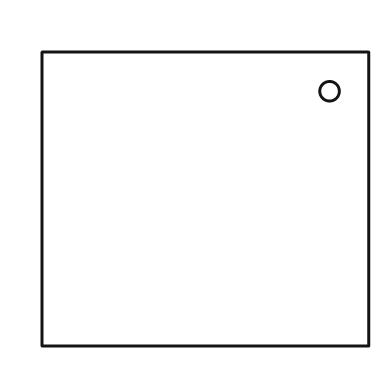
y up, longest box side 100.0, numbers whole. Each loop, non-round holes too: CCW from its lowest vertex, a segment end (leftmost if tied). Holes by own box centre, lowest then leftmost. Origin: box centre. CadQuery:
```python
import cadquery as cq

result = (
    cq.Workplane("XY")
    .moveTo(-50.0, -45.0)
    .lineTo(50.0, -45.0)
    .lineTo(50.0, 45.0)
    .lineTo(-50.0, 45.0)
    .close()
    .moveTo(38.0, 33.0)
    .circle(3.0)
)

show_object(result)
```